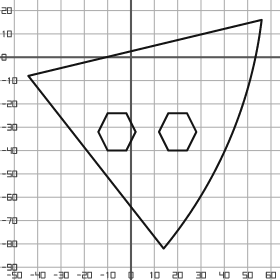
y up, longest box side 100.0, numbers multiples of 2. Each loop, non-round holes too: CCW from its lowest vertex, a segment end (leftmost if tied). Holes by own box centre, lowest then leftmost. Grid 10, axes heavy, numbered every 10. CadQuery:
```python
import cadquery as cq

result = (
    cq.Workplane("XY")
    .moveTo(14.0, -82.0)
    .threePointArc((42.0, -36.0), (56.0, 16.0))
    .lineTo(-44.0, -8.0)
    .close()
    .moveTo(-10.0, -40.0)
    .lineTo(-2.0, -40.0)
    .lineTo(2.0, -32.0)
    .lineTo(-2.0, -24.0)
    .lineTo(-10.0, -24.0)
    .lineTo(-14.0, -32.0)
    .close()
    .moveTo(16.0, -40.0)
    .lineTo(24.0, -40.0)
    .lineTo(28.0, -32.0)
    .lineTo(24.0, -24.0)
    .lineTo(16.0, -24.0)
    .lineTo(12.0, -32.0)
    .close()
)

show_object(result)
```